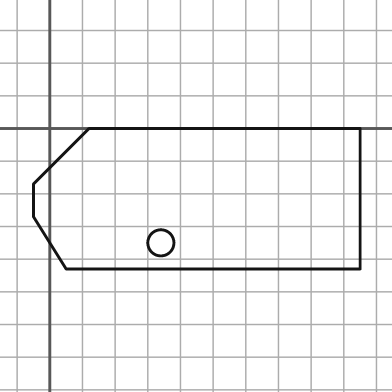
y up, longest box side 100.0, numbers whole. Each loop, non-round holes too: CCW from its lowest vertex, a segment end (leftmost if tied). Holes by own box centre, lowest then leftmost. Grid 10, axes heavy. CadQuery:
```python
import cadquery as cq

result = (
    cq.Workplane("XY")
    .moveTo(5.0, -43.0)
    .lineTo(95.0, -43.0)
    .lineTo(95.0, 0.0)
    .lineTo(12.0, 0.0)
    .lineTo(-5.0, -17.0)
    .lineTo(-5.0, -27.0)
    .close()
    .moveTo(34.0, -35.0)
    .circle(4.0)
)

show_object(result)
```